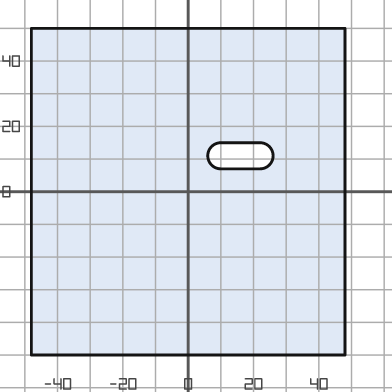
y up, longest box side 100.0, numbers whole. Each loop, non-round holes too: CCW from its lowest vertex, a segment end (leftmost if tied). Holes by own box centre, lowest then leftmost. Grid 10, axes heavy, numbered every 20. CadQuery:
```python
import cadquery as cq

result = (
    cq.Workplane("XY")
    .moveTo(-48.0, -50.0)
    .lineTo(48.0, -50.0)
    .lineTo(48.0, 50.0)
    .lineTo(-48.0, 50.0)
    .close()
    .moveTo(10.0, 7.0)
    .lineTo(22.0, 7.0)
    .threePointArc((26.0, 11.0), (22.0, 15.0))
    .lineTo(10.0, 15.0)
    .threePointArc((6.0, 11.0), (10.0, 7.0))
    .close()
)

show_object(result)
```